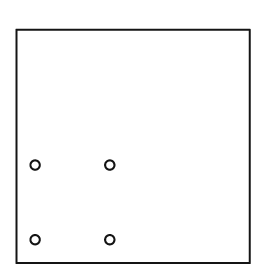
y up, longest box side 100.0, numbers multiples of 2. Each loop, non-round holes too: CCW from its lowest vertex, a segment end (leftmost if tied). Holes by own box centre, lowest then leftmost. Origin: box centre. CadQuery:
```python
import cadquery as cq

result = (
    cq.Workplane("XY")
    .moveTo(-50.0, -50.0)
    .lineTo(50.0, -50.0)
    .lineTo(50.0, 50.0)
    .lineTo(-50.0, 50.0)
    .close()
    .moveTo(-42.0, -40.0)
    .circle(2.0)
    .moveTo(-10.0, -40.0)
    .circle(2.0)
    .moveTo(-42.0, -8.0)
    .circle(2.0)
    .moveTo(-10.0, -8.0)
    .circle(2.0)
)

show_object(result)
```